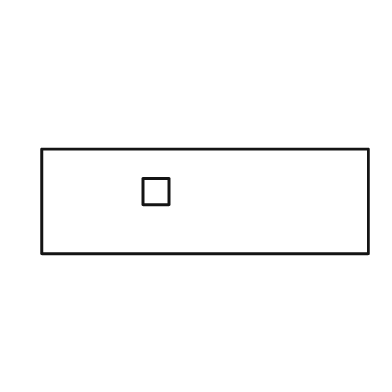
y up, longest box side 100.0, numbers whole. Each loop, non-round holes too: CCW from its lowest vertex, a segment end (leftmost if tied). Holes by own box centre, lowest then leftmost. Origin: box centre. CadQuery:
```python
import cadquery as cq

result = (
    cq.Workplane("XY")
    .moveTo(-50.0, -16.0)
    .lineTo(50.0, -16.0)
    .lineTo(50.0, 16.0)
    .lineTo(-50.0, 16.0)
    .close()
    .moveTo(-19.0, -1.0)
    .lineTo(-11.0, -1.0)
    .lineTo(-11.0, 7.0)
    .lineTo(-19.0, 7.0)
    .close()
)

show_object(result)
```